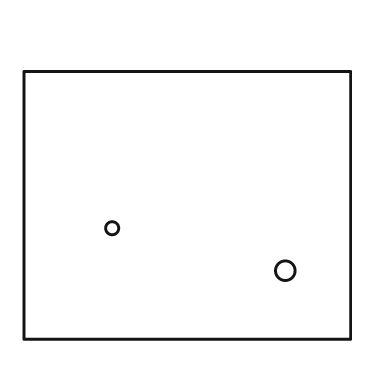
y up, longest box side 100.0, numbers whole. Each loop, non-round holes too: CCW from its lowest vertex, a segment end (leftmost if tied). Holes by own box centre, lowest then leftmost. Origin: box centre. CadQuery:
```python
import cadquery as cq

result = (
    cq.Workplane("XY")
    .moveTo(-50.0, -41.0)
    .lineTo(50.0, -41.0)
    .lineTo(50.0, 41.0)
    .lineTo(-50.0, 41.0)
    .close()
    .moveTo(30.0, -20.0)
    .circle(3.0)
    .moveTo(-23.0, -7.0)
    .circle(2.0)
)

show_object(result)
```